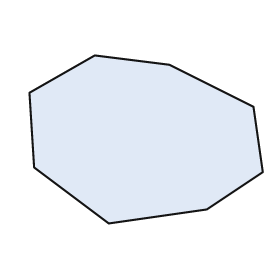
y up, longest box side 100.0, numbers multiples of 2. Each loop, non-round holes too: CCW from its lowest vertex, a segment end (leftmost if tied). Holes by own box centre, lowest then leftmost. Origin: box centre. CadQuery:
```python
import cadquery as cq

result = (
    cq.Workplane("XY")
    .moveTo(-16.0, -36.0)
    .lineTo(26.0, -30.0)
    .lineTo(50.0, -14.0)
    .lineTo(46.0, 14.0)
    .lineTo(10.0, 32.0)
    .lineTo(-22.0, 36.0)
    .lineTo(-50.0, 20.0)
    .lineTo(-48.0, -12.0)
    .close()
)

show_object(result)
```